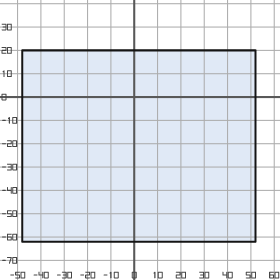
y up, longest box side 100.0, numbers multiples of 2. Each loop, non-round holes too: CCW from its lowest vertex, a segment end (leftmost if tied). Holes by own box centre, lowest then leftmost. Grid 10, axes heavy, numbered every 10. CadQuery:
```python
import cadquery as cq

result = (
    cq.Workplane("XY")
    .moveTo(-48.0, -62.0)
    .lineTo(52.0, -62.0)
    .lineTo(52.0, 20.0)
    .lineTo(-48.0, 20.0)
    .close()
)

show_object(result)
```